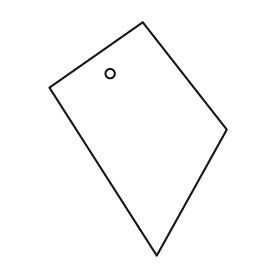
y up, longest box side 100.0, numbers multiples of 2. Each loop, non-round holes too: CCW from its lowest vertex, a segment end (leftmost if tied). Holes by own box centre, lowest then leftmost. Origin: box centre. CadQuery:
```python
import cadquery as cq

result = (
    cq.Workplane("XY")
    .moveTo(8.0, -50.0)
    .lineTo(38.0, 4.0)
    .lineTo(2.0, 50.0)
    .lineTo(-38.0, 22.0)
    .close()
    .moveTo(-12.0, 28.0)
    .circle(2.0)
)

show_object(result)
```